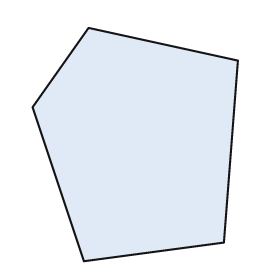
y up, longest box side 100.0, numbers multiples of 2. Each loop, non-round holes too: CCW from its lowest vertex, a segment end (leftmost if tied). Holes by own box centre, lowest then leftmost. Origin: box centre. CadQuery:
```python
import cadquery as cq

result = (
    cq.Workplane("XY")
    .moveTo(-22.0, -50.0)
    .lineTo(38.0, -42.0)
    .lineTo(44.0, 36.0)
    .lineTo(-20.0, 50.0)
    .lineTo(-44.0, 16.0)
    .close()
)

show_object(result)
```